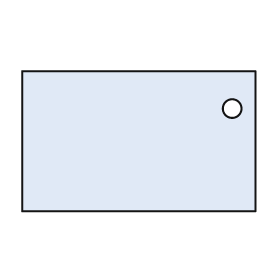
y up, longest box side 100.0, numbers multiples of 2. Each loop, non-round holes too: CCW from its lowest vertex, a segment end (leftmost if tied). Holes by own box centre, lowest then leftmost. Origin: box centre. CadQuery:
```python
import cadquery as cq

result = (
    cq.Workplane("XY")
    .moveTo(-50.0, -30.0)
    .lineTo(50.0, -30.0)
    .lineTo(50.0, 30.0)
    .lineTo(-50.0, 30.0)
    .close()
    .moveTo(40.0, 14.0)
    .circle(4.0)
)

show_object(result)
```